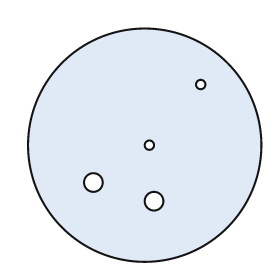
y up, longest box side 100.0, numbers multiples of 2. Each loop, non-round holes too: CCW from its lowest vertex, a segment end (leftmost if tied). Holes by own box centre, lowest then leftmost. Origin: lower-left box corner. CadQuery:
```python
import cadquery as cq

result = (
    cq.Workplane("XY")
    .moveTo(50.0, 50.0)
    .circle(50.0)
    .moveTo(54.0, 26.0)
    .circle(4.0)
    .moveTo(28.0, 34.0)
    .circle(4.0)
    .moveTo(52.0, 50.0)
    .circle(2.0)
    .moveTo(74.0, 76.0)
    .circle(2.0)
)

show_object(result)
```